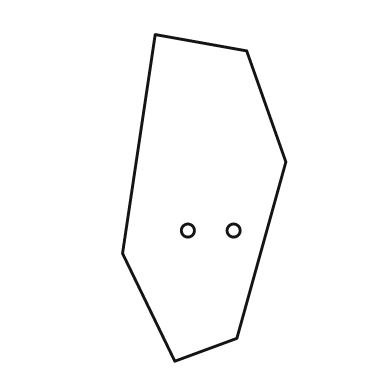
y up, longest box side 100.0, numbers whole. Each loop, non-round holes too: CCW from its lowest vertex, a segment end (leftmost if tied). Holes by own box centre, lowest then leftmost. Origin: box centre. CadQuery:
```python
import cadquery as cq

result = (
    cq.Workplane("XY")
    .moveTo(-9.0, -50.0)
    .lineTo(10.0, -43.0)
    .lineTo(25.0, 11.0)
    .lineTo(13.0, 45.0)
    .lineTo(-15.0, 50.0)
    .lineTo(-25.0, -17.0)
    .close()
    .moveTo(-5.0, -10.0)
    .circle(2.0)
    .moveTo(9.0, -10.0)
    .circle(2.0)
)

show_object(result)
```